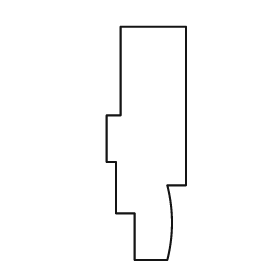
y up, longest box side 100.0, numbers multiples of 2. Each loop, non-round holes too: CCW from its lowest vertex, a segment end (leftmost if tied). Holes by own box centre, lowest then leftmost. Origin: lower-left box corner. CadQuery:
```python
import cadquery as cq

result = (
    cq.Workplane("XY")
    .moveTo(12.0, 0.0)
    .lineTo(26.0, 0.0)
    .threePointArc((28.0, 16.0), (26.0, 32.0))
    .lineTo(34.0, 32.0)
    .lineTo(34.0, 100.0)
    .lineTo(6.0, 100.0)
    .lineTo(6.0, 62.0)
    .lineTo(0.0, 62.0)
    .lineTo(0.0, 42.0)
    .lineTo(4.0, 42.0)
    .lineTo(4.0, 20.0)
    .lineTo(12.0, 20.0)
    .close()
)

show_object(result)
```